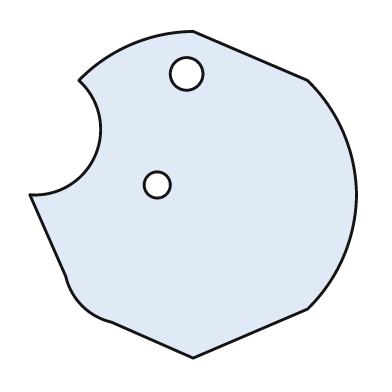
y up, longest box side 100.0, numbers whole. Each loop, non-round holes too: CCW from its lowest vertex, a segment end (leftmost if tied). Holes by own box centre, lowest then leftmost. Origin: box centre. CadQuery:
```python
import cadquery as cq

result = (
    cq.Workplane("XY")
    .moveTo(0.0, -50.0)
    .lineTo(35.0, -35.0)
    .threePointArc((46.0, -19.0), (50.0, 0.0))
    .threePointArc((46.0, 19.0), (35.0, 35.0))
    .lineTo(0.0, 50.0)
    .threePointArc((-19.0, 46.0), (-35.0, 35.0))
    .threePointArc((-30.0, 12.0), (-50.0, 0.0))
    .lineTo(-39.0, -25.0)
    .threePointArc((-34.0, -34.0), (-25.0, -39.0))
    .close()
    .moveTo(-11.0, 3.0)
    .circle(4.0)
    .moveTo(-2.0, 37.0)
    .circle(5.0)
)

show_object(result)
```